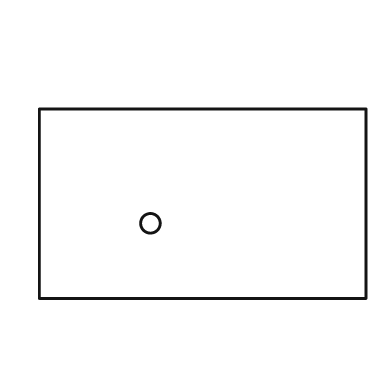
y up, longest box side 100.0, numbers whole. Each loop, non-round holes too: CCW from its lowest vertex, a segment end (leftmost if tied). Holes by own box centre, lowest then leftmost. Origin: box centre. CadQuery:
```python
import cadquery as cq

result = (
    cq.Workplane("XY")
    .moveTo(-50.0, -29.0)
    .lineTo(50.0, -29.0)
    .lineTo(50.0, 29.0)
    .lineTo(-50.0, 29.0)
    .close()
    .moveTo(-16.0, -6.0)
    .circle(3.0)
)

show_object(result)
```